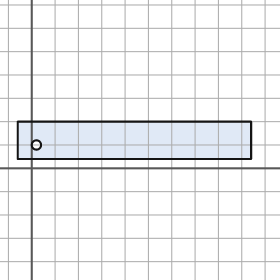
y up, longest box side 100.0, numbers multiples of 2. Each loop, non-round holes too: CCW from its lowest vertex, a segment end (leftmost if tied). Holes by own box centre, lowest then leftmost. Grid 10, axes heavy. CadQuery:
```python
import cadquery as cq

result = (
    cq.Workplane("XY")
    .moveTo(-6.0, 4.0)
    .lineTo(94.0, 4.0)
    .lineTo(94.0, 20.0)
    .lineTo(-6.0, 20.0)
    .close()
    .moveTo(2.0, 10.0)
    .circle(2.0)
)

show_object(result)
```